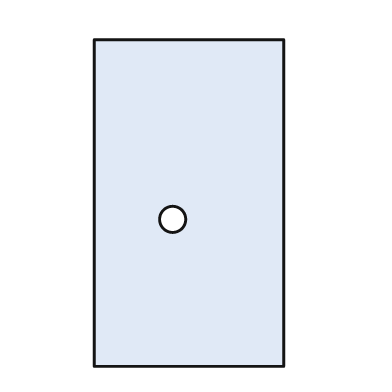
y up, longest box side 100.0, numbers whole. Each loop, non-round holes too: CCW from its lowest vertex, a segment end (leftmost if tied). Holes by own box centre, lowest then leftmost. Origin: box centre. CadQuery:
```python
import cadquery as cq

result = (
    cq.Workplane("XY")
    .moveTo(-29.0, -50.0)
    .lineTo(29.0, -50.0)
    .lineTo(29.0, 50.0)
    .lineTo(-29.0, 50.0)
    .close()
    .moveTo(-5.0, -5.0)
    .circle(4.0)
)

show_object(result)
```